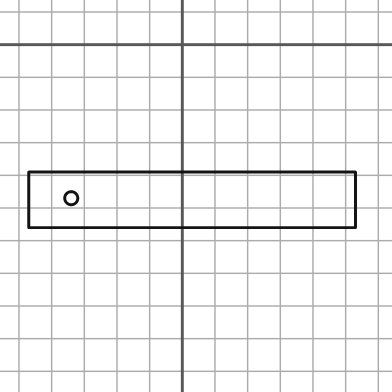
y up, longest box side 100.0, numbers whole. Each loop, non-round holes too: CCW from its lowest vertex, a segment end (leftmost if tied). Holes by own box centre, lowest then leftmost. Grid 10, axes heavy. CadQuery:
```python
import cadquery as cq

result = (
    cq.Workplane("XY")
    .moveTo(-47.0, -56.0)
    .lineTo(53.0, -56.0)
    .lineTo(53.0, -39.0)
    .lineTo(-47.0, -39.0)
    .close()
    .moveTo(-34.0, -47.0)
    .circle(2.0)
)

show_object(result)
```